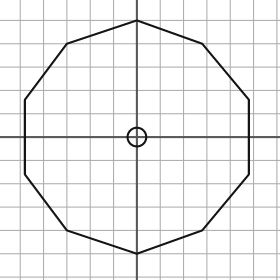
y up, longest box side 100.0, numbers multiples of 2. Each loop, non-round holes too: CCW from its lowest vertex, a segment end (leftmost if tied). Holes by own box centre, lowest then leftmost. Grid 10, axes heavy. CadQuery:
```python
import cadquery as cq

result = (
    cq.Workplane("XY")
    .moveTo(0.0, -50.0)
    .lineTo(28.0, -40.0)
    .lineTo(48.0, -16.0)
    .lineTo(48.0, 16.0)
    .lineTo(28.0, 40.0)
    .lineTo(0.0, 50.0)
    .lineTo(-30.0, 40.0)
    .lineTo(-48.0, 16.0)
    .lineTo(-48.0, -16.0)
    .lineTo(-30.0, -40.0)
    .close()
    .moveTo(0.0, 0.0)
    .circle(4.0)
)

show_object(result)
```